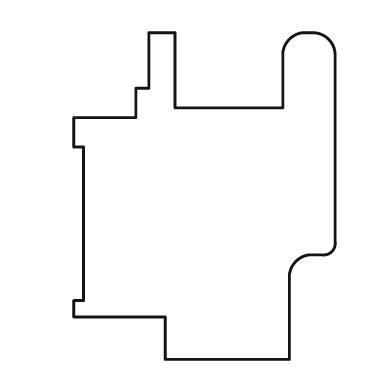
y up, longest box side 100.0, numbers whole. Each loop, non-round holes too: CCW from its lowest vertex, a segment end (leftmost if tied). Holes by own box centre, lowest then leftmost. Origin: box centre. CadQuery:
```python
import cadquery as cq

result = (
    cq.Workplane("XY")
    .moveTo(-12.0, -50.0)
    .lineTo(26.0, -50.0)
    .lineTo(26.0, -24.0)
    .threePointArc((28.0, -20.0), (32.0, -18.0))
    .lineTo(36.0, -18.0)
    .threePointArc((39.0, -17.0), (40.0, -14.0))
    .lineTo(40.0, 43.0)
    .threePointArc((38.0, 48.0), (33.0, 50.0))
    .lineTo(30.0, 50.0)
    .threePointArc((26.0, 48.0), (24.0, 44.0))
    .lineTo(24.0, 27.0)
    .lineTo(-9.0, 27.0)
    .lineTo(-9.0, 50.0)
    .lineTo(-17.0, 50.0)
    .lineTo(-17.0, 33.0)
    .lineTo(-21.0, 33.0)
    .lineTo(-21.0, 24.0)
    .lineTo(-40.0, 24.0)
    .lineTo(-40.0, 15.0)
    .lineTo(-37.0, 15.0)
    .lineTo(-37.0, -32.0)
    .lineTo(-40.0, -32.0)
    .lineTo(-40.0, -37.0)
    .lineTo(-12.0, -37.0)
    .close()
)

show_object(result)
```